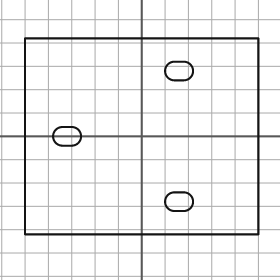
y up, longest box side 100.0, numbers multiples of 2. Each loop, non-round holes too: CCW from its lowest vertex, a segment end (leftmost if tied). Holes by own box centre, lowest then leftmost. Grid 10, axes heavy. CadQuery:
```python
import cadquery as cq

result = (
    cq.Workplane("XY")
    .moveTo(-50.0, -42.0)
    .lineTo(50.0, -42.0)
    .lineTo(50.0, 42.0)
    .lineTo(-50.0, 42.0)
    .close()
    .moveTo(14.0, -32.0)
    .lineTo(18.0, -32.0)
    .threePointArc((22.0, -28.0), (18.0, -24.0))
    .lineTo(14.0, -24.0)
    .threePointArc((10.0, -28.0), (14.0, -32.0))
    .close()
    .moveTo(-34.0, -4.0)
    .lineTo(-30.0, -4.0)
    .threePointArc((-26.0, 0.0), (-30.0, 4.0))
    .lineTo(-34.0, 4.0)
    .threePointArc((-38.0, 0.0), (-34.0, -4.0))
    .close()
    .moveTo(14.0, 24.0)
    .lineTo(18.0, 24.0)
    .threePointArc((22.0, 28.0), (18.0, 32.0))
    .lineTo(14.0, 32.0)
    .threePointArc((10.0, 28.0), (14.0, 24.0))
    .close()
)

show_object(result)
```